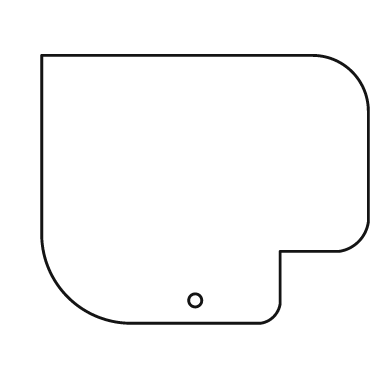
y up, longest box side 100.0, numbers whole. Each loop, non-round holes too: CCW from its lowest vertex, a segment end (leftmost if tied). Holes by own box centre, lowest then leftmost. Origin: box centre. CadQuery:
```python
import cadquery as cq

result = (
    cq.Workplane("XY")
    .moveTo(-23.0, -41.0)
    .lineTo(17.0, -41.0)
    .threePointArc((21.0, -39.0), (23.0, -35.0))
    .lineTo(23.0, -19.0)
    .lineTo(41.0, -19.0)
    .threePointArc((47.0, -16.0), (50.0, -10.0))
    .lineTo(50.0, 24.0)
    .threePointArc((45.0, 36.0), (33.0, 41.0))
    .lineTo(-50.0, 41.0)
    .lineTo(-50.0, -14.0)
    .threePointArc((-42.0, -33.0), (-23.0, -41.0))
    .close()
    .moveTo(-3.0, -34.0)
    .circle(2.0)
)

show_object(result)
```